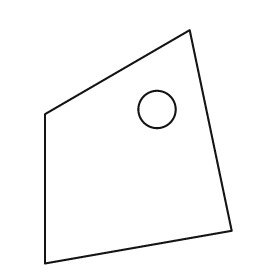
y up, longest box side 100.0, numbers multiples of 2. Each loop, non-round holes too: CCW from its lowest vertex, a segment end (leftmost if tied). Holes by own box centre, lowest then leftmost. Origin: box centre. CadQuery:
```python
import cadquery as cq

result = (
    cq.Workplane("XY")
    .moveTo(-40.0, -50.0)
    .lineTo(40.0, -36.0)
    .lineTo(22.0, 50.0)
    .lineTo(-40.0, 14.0)
    .close()
    .moveTo(8.0, 16.0)
    .circle(8.0)
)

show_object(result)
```